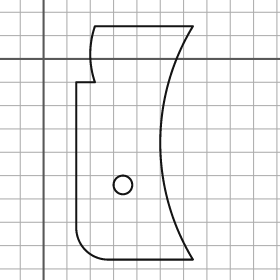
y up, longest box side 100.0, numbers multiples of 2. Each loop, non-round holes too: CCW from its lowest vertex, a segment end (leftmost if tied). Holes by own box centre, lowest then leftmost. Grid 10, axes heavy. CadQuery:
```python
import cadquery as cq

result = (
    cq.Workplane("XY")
    .moveTo(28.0, -86.0)
    .lineTo(64.0, -86.0)
    .threePointArc((50.0, -36.0), (64.0, 14.0))
    .lineTo(22.0, 14.0)
    .threePointArc((20.0, 2.0), (22.0, -10.0))
    .lineTo(14.0, -10.0)
    .lineTo(14.0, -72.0)
    .threePointArc((18.0, -82.0), (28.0, -86.0))
    .close()
    .moveTo(34.0, -54.0)
    .circle(4.0)
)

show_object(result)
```